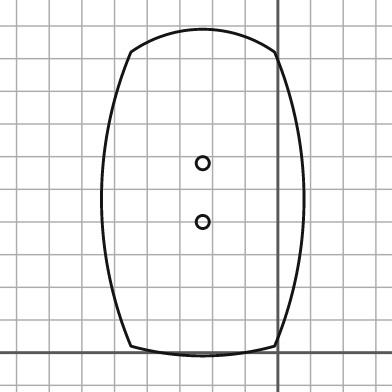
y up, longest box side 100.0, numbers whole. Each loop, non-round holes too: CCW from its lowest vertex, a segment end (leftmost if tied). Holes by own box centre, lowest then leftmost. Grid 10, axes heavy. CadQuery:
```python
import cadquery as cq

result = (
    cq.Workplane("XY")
    .moveTo(-45.0, 2.0)
    .threePointArc((-23.0, -1.0), (-1.0, 2.0))
    .threePointArc((8.0, 47.0), (-1.0, 92.0))
    .threePointArc((-23.0, 99.0), (-45.0, 92.0))
    .threePointArc((-54.0, 47.0), (-45.0, 2.0))
    .close()
    .moveTo(-23.0, 40.0)
    .circle(2.0)
    .moveTo(-23.0, 58.0)
    .circle(2.0)
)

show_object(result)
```